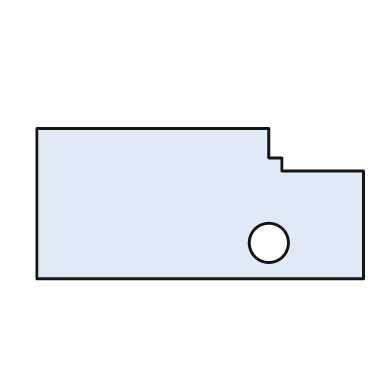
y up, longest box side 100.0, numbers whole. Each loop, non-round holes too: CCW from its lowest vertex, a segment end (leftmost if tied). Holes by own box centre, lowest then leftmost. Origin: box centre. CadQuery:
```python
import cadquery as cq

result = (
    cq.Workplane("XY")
    .moveTo(-50.0, -23.0)
    .lineTo(50.0, -23.0)
    .lineTo(50.0, 10.0)
    .lineTo(25.0, 10.0)
    .lineTo(25.0, 14.0)
    .lineTo(21.0, 14.0)
    .lineTo(21.0, 23.0)
    .lineTo(-50.0, 23.0)
    .close()
    .moveTo(21.0, -12.0)
    .circle(6.0)
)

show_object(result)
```